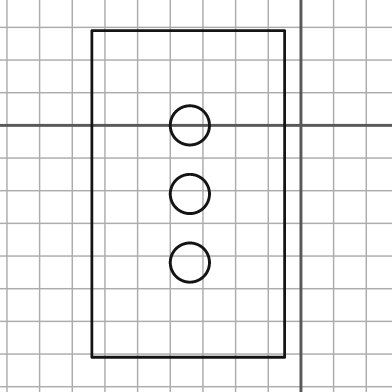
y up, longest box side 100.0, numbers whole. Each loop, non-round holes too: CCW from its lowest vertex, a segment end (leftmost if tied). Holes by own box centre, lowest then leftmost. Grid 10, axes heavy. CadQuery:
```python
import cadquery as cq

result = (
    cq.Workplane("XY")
    .moveTo(-64.0, -71.0)
    .lineTo(-5.0, -71.0)
    .lineTo(-5.0, 29.0)
    .lineTo(-64.0, 29.0)
    .close()
    .moveTo(-34.0, -42.0)
    .circle(6.0)
    .moveTo(-34.0, -21.0)
    .circle(6.0)
    .moveTo(-34.0, 0.0)
    .circle(6.0)
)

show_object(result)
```